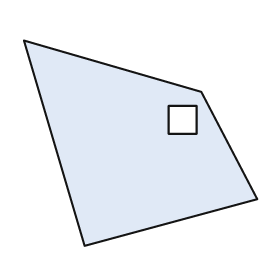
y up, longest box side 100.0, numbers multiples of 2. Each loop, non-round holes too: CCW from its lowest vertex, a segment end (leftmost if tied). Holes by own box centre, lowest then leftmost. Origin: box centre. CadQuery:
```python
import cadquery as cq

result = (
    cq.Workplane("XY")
    .moveTo(-24.0, -44.0)
    .lineTo(50.0, -24.0)
    .lineTo(26.0, 22.0)
    .lineTo(-50.0, 44.0)
    .close()
    .moveTo(12.0, 4.0)
    .lineTo(24.0, 4.0)
    .lineTo(24.0, 16.0)
    .lineTo(12.0, 16.0)
    .close()
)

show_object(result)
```